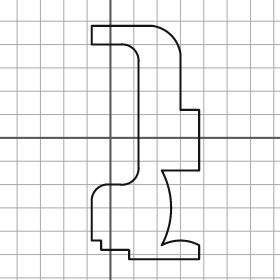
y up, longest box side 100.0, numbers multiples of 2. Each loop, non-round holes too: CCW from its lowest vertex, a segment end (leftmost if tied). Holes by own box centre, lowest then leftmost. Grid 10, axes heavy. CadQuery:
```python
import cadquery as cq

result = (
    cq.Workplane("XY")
    .moveTo(8.0, -52.0)
    .lineTo(38.0, -52.0)
    .lineTo(38.0, -46.0)
    .threePointArc((30.0, -44.0), (22.0, -46.0))
    .threePointArc((26.0, -30.0), (22.0, -14.0))
    .lineTo(38.0, -14.0)
    .lineTo(38.0, 12.0)
    .lineTo(30.0, 12.0)
    .lineTo(30.0, 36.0)
    .threePointArc((26.0, 44.0), (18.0, 48.0))
    .lineTo(-8.0, 48.0)
    .lineTo(-8.0, 40.0)
    .lineTo(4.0, 40.0)
    .threePointArc((10.0, 38.0), (12.0, 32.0))
    .lineTo(12.0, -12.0)
    .threePointArc((10.0, -18.0), (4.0, -20.0))
    .lineTo(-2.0, -20.0)
    .threePointArc((-6.0, -22.0), (-8.0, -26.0))
    .lineTo(-8.0, -44.0)
    .lineTo(-4.0, -44.0)
    .lineTo(-4.0, -48.0)
    .lineTo(8.0, -48.0)
    .close()
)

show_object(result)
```